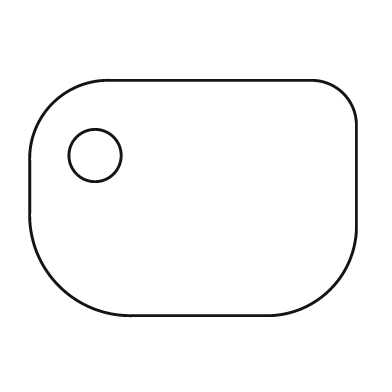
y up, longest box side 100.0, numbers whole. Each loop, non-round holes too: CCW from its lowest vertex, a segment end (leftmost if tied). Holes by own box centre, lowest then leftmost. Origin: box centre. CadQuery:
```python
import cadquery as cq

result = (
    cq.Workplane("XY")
    .moveTo(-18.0, -36.0)
    .lineTo(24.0, -36.0)
    .threePointArc((42.0, -28.0), (50.0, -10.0))
    .lineTo(50.0, 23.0)
    .threePointArc((46.0, 32.0), (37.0, 36.0))
    .lineTo(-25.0, 36.0)
    .threePointArc((-43.0, 29.0), (-50.0, 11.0))
    .lineTo(-50.0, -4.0)
    .threePointArc((-41.0, -27.0), (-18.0, -36.0))
    .close()
    .moveTo(-30.0, 13.0)
    .circle(8.0)
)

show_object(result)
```